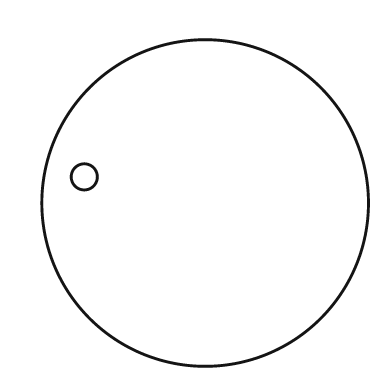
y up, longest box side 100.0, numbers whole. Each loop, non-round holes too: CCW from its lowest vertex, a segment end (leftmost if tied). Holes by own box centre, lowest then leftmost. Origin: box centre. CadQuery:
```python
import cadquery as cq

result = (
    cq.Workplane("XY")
    .moveTo(0.0, 0.0)
    .circle(50.0)
    .moveTo(-37.0, 8.0)
    .circle(4.0)
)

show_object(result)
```